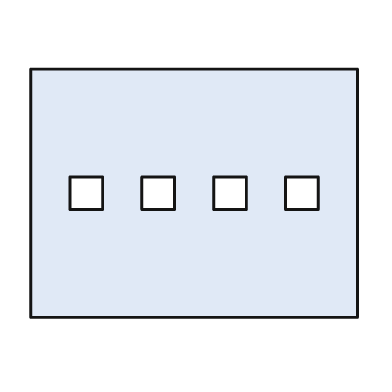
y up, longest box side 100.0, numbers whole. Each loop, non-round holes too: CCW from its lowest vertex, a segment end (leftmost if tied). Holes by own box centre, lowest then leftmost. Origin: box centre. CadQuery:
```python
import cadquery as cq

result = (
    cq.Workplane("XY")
    .moveTo(-50.0, -38.0)
    .lineTo(50.0, -38.0)
    .lineTo(50.0, 38.0)
    .lineTo(-50.0, 38.0)
    .close()
    .moveTo(-38.0, -5.0)
    .lineTo(-28.0, -5.0)
    .lineTo(-28.0, 5.0)
    .lineTo(-38.0, 5.0)
    .close()
    .moveTo(-16.0, -5.0)
    .lineTo(-6.0, -5.0)
    .lineTo(-6.0, 5.0)
    .lineTo(-16.0, 5.0)
    .close()
    .moveTo(6.0, -5.0)
    .lineTo(16.0, -5.0)
    .lineTo(16.0, 5.0)
    .lineTo(6.0, 5.0)
    .close()
    .moveTo(28.0, -5.0)
    .lineTo(38.0, -5.0)
    .lineTo(38.0, 5.0)
    .lineTo(28.0, 5.0)
    .close()
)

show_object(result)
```